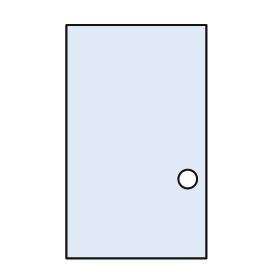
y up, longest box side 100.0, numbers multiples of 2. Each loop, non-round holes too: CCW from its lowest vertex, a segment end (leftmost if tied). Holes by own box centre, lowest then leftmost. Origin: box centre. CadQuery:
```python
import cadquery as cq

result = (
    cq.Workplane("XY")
    .moveTo(-30.0, -50.0)
    .lineTo(30.0, -50.0)
    .lineTo(30.0, 50.0)
    .lineTo(-30.0, 50.0)
    .close()
    .moveTo(22.0, -16.0)
    .circle(4.0)
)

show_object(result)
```